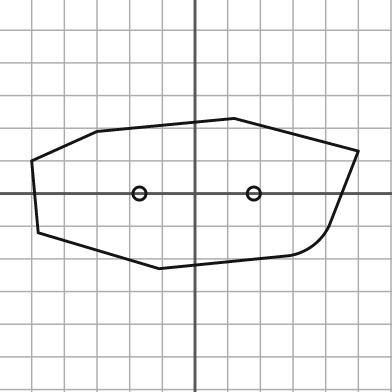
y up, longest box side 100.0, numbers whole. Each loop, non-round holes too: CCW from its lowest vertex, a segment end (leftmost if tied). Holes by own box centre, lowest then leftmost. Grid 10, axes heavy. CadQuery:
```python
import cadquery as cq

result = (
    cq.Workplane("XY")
    .moveTo(-11.0, -23.0)
    .lineTo(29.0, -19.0)
    .threePointArc((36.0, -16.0), (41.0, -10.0))
    .lineTo(50.0, 13.0)
    .lineTo(12.0, 23.0)
    .lineTo(-30.0, 19.0)
    .lineTo(-50.0, 10.0)
    .lineTo(-48.0, -12.0)
    .close()
    .moveTo(-17.0, 0.0)
    .circle(2.0)
    .moveTo(18.0, 0.0)
    .circle(2.0)
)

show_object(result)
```